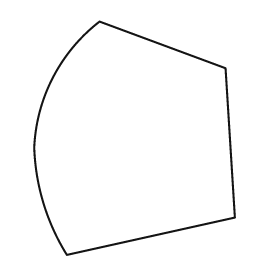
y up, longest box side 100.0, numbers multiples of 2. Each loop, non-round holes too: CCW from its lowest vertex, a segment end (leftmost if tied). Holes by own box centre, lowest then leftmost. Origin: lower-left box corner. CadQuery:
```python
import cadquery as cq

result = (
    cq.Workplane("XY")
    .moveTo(14.0, 0.0)
    .lineTo(86.0, 16.0)
    .lineTo(82.0, 80.0)
    .lineTo(28.0, 100.0)
    .threePointArc((8.0, 76.0), (0.0, 46.0))
    .threePointArc((4.0, 22.0), (14.0, 0.0))
    .close()
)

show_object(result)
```